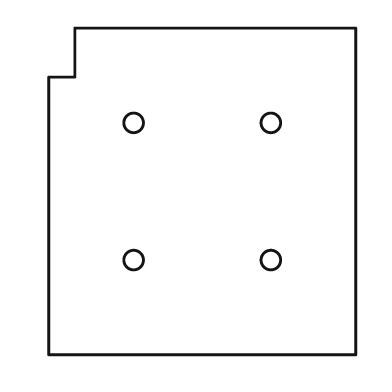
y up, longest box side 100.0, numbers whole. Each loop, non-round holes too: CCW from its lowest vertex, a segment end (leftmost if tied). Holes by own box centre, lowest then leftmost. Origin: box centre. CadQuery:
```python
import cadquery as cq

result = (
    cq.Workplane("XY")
    .moveTo(-47.0, -50.0)
    .lineTo(47.0, -50.0)
    .lineTo(47.0, 50.0)
    .lineTo(-39.0, 50.0)
    .lineTo(-39.0, 35.0)
    .lineTo(-47.0, 35.0)
    .close()
    .moveTo(-21.0, -21.0)
    .circle(3.0)
    .moveTo(21.0, -21.0)
    .circle(3.0)
    .moveTo(-21.0, 21.0)
    .circle(3.0)
    .moveTo(21.0, 21.0)
    .circle(3.0)
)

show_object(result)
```